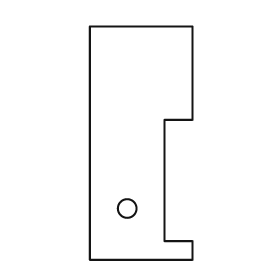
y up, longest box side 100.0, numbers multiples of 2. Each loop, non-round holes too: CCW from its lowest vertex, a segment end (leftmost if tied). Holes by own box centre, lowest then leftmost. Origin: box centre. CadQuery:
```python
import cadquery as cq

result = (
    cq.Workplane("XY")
    .moveTo(-22.0, -50.0)
    .lineTo(22.0, -50.0)
    .lineTo(22.0, -42.0)
    .lineTo(10.0, -42.0)
    .lineTo(10.0, 10.0)
    .lineTo(22.0, 10.0)
    .lineTo(22.0, 50.0)
    .lineTo(-22.0, 50.0)
    .close()
    .moveTo(-6.0, -28.0)
    .circle(4.0)
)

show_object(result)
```